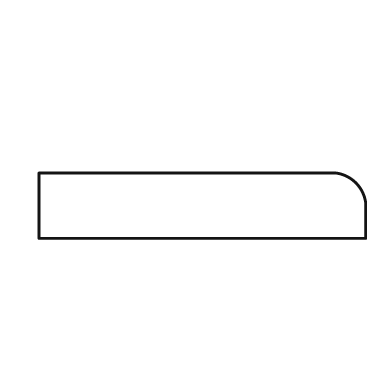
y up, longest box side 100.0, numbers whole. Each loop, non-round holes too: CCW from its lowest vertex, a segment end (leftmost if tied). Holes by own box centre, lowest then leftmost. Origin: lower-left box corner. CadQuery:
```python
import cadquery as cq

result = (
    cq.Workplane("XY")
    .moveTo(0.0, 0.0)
    .lineTo(100.0, 0.0)
    .lineTo(100.0, 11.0)
    .threePointArc((97.0, 17.0), (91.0, 20.0))
    .lineTo(0.0, 20.0)
    .close()
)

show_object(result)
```